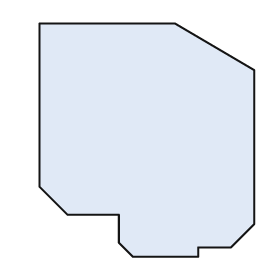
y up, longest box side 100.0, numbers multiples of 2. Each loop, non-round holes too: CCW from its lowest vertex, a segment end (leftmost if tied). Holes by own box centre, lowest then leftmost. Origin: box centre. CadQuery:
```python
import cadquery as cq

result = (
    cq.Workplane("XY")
    .moveTo(-6.0, -50.0)
    .lineTo(22.0, -50.0)
    .lineTo(22.0, -46.0)
    .lineTo(36.0, -46.0)
    .lineTo(46.0, -36.0)
    .lineTo(46.0, 30.0)
    .lineTo(12.0, 50.0)
    .lineTo(-46.0, 50.0)
    .lineTo(-46.0, -20.0)
    .lineTo(-34.0, -32.0)
    .lineTo(-12.0, -32.0)
    .lineTo(-12.0, -44.0)
    .close()
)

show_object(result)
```